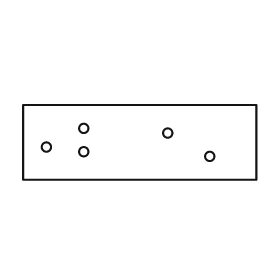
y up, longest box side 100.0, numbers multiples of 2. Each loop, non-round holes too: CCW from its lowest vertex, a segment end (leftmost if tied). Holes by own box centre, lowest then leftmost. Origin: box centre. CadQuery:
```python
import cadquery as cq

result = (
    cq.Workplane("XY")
    .moveTo(-50.0, -16.0)
    .lineTo(50.0, -16.0)
    .lineTo(50.0, 16.0)
    .lineTo(-50.0, 16.0)
    .close()
    .moveTo(30.0, -6.0)
    .circle(2.0)
    .moveTo(-24.0, -4.0)
    .circle(2.0)
    .moveTo(-40.0, -2.0)
    .circle(2.0)
    .moveTo(12.0, 4.0)
    .circle(2.0)
    .moveTo(-24.0, 6.0)
    .circle(2.0)
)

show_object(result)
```